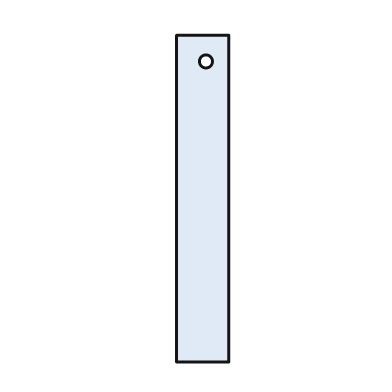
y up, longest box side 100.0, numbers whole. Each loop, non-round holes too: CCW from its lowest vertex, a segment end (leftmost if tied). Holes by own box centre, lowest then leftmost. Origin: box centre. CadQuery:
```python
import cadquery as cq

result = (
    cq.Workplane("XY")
    .moveTo(-8.0, -50.0)
    .lineTo(8.0, -50.0)
    .lineTo(8.0, 50.0)
    .lineTo(-8.0, 50.0)
    .close()
    .moveTo(1.0, 42.0)
    .circle(2.0)
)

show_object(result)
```